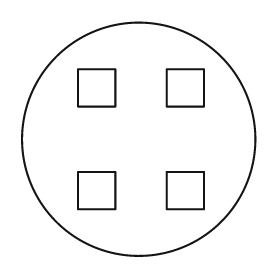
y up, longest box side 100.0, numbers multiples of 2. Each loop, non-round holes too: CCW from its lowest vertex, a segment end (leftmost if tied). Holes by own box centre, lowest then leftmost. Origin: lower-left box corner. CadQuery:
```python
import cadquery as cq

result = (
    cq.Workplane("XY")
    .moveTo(50.0, 50.0)
    .circle(50.0)
    .moveTo(24.0, 20.0)
    .lineTo(40.0, 20.0)
    .lineTo(40.0, 36.0)
    .lineTo(24.0, 36.0)
    .close()
    .moveTo(62.0, 20.0)
    .lineTo(78.0, 20.0)
    .lineTo(78.0, 36.0)
    .lineTo(62.0, 36.0)
    .close()
    .moveTo(24.0, 64.0)
    .lineTo(40.0, 64.0)
    .lineTo(40.0, 80.0)
    .lineTo(24.0, 80.0)
    .close()
    .moveTo(62.0, 64.0)
    .lineTo(78.0, 64.0)
    .lineTo(78.0, 80.0)
    .lineTo(62.0, 80.0)
    .close()
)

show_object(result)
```